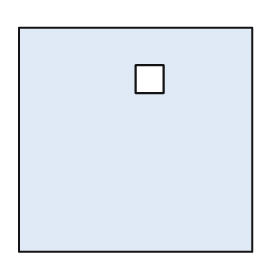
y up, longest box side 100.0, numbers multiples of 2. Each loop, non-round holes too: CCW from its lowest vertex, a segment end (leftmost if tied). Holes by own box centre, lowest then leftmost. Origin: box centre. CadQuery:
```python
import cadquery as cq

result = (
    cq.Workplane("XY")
    .moveTo(-50.0, -48.0)
    .lineTo(50.0, -48.0)
    .lineTo(50.0, 48.0)
    .lineTo(-50.0, 48.0)
    .close()
    .moveTo(0.0, 20.0)
    .lineTo(12.0, 20.0)
    .lineTo(12.0, 32.0)
    .lineTo(0.0, 32.0)
    .close()
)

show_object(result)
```